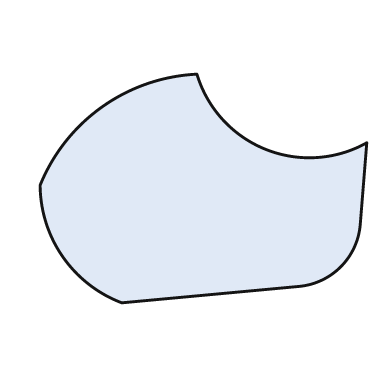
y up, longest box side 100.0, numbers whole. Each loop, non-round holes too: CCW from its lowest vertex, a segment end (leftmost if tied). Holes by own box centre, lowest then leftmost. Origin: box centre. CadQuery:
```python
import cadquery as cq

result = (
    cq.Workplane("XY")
    .moveTo(-25.0, -35.0)
    .lineTo(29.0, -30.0)
    .threePointArc((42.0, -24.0), (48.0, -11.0))
    .lineTo(50.0, 14.0)
    .threePointArc((19.0, 12.0), (-2.0, 35.0))
    .threePointArc((-31.0, 25.0), (-50.0, 1.0))
    .threePointArc((-43.0, -21.0), (-25.0, -35.0))
    .close()
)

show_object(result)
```